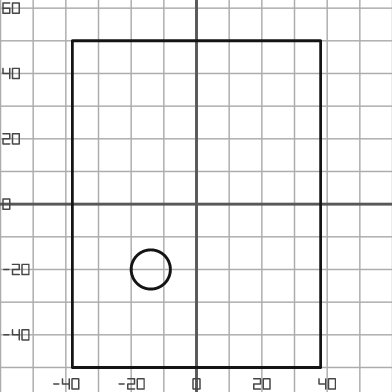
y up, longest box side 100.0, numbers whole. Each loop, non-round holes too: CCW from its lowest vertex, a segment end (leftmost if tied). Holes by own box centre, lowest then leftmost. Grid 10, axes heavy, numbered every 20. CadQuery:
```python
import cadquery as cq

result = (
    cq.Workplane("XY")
    .moveTo(-38.0, -50.0)
    .lineTo(38.0, -50.0)
    .lineTo(38.0, 50.0)
    .lineTo(-38.0, 50.0)
    .close()
    .moveTo(-14.0, -20.0)
    .circle(6.0)
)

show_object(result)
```